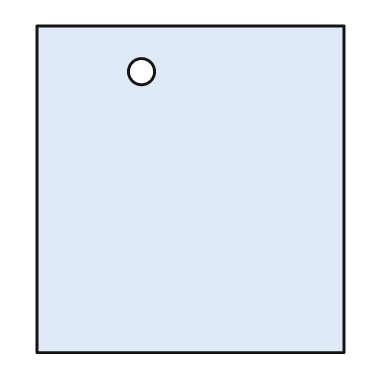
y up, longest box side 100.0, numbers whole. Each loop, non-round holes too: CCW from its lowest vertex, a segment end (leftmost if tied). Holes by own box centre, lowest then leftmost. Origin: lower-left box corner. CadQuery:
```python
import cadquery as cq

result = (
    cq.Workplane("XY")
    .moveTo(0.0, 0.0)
    .lineTo(94.0, 0.0)
    .lineTo(94.0, 100.0)
    .lineTo(0.0, 100.0)
    .close()
    .moveTo(32.0, 86.0)
    .circle(4.0)
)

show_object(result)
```